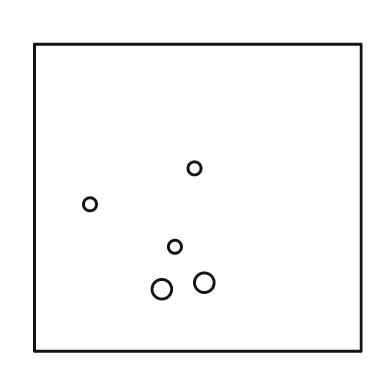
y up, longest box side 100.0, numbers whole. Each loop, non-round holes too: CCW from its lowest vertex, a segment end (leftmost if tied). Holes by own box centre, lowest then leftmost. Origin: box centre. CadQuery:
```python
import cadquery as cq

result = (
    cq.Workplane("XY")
    .moveTo(-50.0, -47.0)
    .lineTo(50.0, -47.0)
    .lineTo(50.0, 47.0)
    .lineTo(-50.0, 47.0)
    .close()
    .moveTo(-11.0, -28.0)
    .circle(3.0)
    .moveTo(2.0, -26.0)
    .circle(3.0)
    .moveTo(-7.0, -15.0)
    .circle(2.0)
    .moveTo(-33.0, -2.0)
    .circle(2.0)
    .moveTo(-1.0, 9.0)
    .circle(2.0)
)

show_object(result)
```